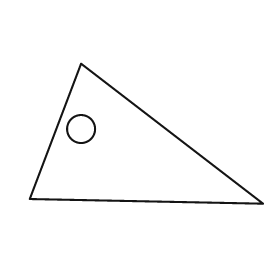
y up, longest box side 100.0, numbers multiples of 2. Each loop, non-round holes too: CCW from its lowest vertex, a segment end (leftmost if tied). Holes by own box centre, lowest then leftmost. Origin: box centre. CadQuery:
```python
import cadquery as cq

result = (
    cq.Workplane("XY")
    .moveTo(50.0, -30.0)
    .lineTo(-28.0, 30.0)
    .lineTo(-50.0, -28.0)
    .close()
    .moveTo(-28.0, 2.0)
    .circle(6.0)
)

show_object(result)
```